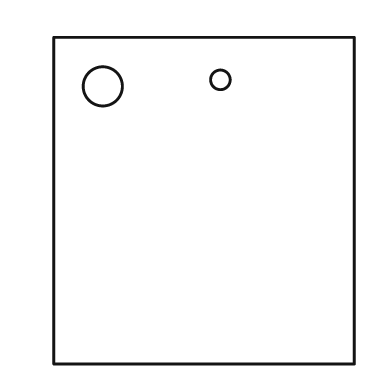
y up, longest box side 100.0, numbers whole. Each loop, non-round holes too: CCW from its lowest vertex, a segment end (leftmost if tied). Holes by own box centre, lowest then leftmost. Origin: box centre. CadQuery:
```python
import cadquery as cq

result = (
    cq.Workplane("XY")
    .moveTo(-46.0, -50.0)
    .lineTo(46.0, -50.0)
    .lineTo(46.0, 50.0)
    .lineTo(-46.0, 50.0)
    .close()
    .moveTo(-31.0, 35.0)
    .circle(6.0)
    .moveTo(5.0, 37.0)
    .circle(3.0)
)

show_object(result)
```